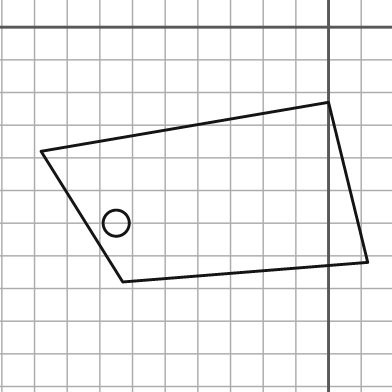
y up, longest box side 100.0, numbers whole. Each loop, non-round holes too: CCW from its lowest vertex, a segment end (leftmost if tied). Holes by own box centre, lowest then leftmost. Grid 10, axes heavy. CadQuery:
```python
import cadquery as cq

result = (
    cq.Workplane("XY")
    .moveTo(-63.0, -78.0)
    .lineTo(12.0, -72.0)
    .lineTo(0.0, -23.0)
    .lineTo(-88.0, -38.0)
    .close()
    .moveTo(-65.0, -60.0)
    .circle(4.0)
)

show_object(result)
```